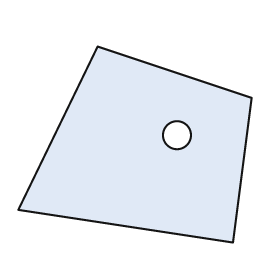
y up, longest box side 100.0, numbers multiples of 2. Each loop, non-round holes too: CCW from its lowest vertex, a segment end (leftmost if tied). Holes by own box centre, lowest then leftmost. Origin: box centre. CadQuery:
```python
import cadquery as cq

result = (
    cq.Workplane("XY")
    .moveTo(42.0, -42.0)
    .lineTo(50.0, 20.0)
    .lineTo(-16.0, 42.0)
    .lineTo(-50.0, -28.0)
    .close()
    .moveTo(18.0, 4.0)
    .circle(6.0)
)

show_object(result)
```